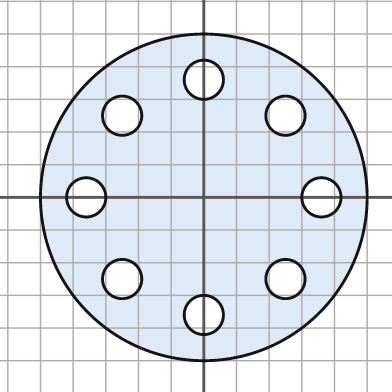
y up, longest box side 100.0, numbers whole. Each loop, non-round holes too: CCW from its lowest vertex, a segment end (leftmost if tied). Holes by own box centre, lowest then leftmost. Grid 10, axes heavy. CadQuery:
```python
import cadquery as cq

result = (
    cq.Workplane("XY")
    .moveTo(0.0, 0.0)
    .circle(50.0)
    .moveTo(0.0, -36.0)
    .circle(6.0)
    .moveTo(-25.0, -25.0)
    .circle(6.0)
    .moveTo(25.0, -25.0)
    .circle(6.0)
    .moveTo(-36.0, 0.0)
    .circle(6.0)
    .moveTo(36.0, 0.0)
    .circle(6.0)
    .moveTo(-25.0, 25.0)
    .circle(6.0)
    .moveTo(25.0, 25.0)
    .circle(6.0)
    .moveTo(0.0, 36.0)
    .circle(6.0)
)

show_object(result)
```